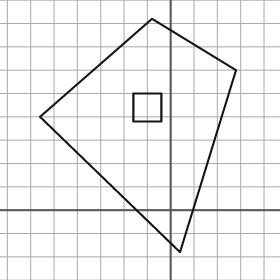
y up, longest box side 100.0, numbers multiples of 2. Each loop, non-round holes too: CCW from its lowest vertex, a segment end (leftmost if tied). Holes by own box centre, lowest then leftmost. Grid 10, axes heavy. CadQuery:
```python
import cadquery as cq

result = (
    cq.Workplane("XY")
    .moveTo(4.0, -18.0)
    .lineTo(28.0, 60.0)
    .lineTo(-8.0, 82.0)
    .lineTo(-56.0, 40.0)
    .close()
    .moveTo(-16.0, 38.0)
    .lineTo(-4.0, 38.0)
    .lineTo(-4.0, 50.0)
    .lineTo(-16.0, 50.0)
    .close()
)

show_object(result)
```